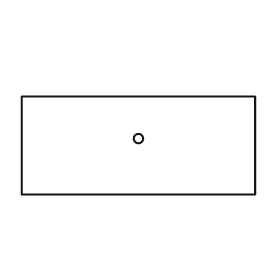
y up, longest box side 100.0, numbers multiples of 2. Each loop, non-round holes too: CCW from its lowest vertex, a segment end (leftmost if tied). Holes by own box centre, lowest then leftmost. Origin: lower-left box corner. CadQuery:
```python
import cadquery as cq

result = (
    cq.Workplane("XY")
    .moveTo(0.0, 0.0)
    .lineTo(100.0, 0.0)
    .lineTo(100.0, 42.0)
    .lineTo(0.0, 42.0)
    .close()
    .moveTo(50.0, 24.0)
    .circle(2.0)
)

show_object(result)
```